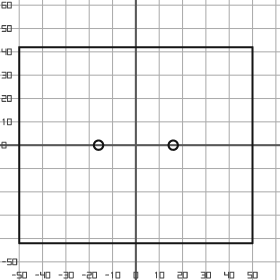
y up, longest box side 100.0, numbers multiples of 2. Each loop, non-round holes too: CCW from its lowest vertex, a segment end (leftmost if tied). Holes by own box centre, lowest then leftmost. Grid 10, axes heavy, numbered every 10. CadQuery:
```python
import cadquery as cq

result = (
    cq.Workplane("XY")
    .moveTo(-50.0, -42.0)
    .lineTo(50.0, -42.0)
    .lineTo(50.0, 42.0)
    .lineTo(-50.0, 42.0)
    .close()
    .moveTo(-16.0, 0.0)
    .circle(2.0)
    .moveTo(16.0, 0.0)
    .circle(2.0)
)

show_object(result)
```